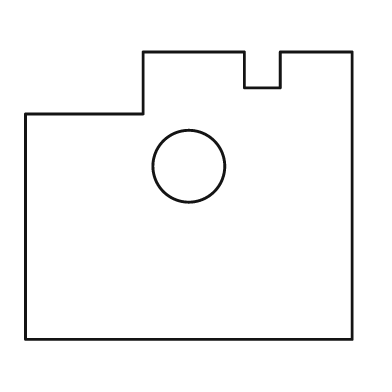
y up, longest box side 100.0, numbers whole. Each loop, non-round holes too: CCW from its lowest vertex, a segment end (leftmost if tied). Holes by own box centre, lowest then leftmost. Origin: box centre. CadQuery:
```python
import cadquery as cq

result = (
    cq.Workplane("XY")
    .moveTo(-50.0, -44.0)
    .lineTo(50.0, -44.0)
    .lineTo(50.0, 44.0)
    .lineTo(28.0, 44.0)
    .lineTo(28.0, 33.0)
    .lineTo(17.0, 33.0)
    .lineTo(17.0, 44.0)
    .lineTo(-14.0, 44.0)
    .lineTo(-14.0, 25.0)
    .lineTo(-50.0, 25.0)
    .close()
    .moveTo(0.0, 9.0)
    .circle(11.0)
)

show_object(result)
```